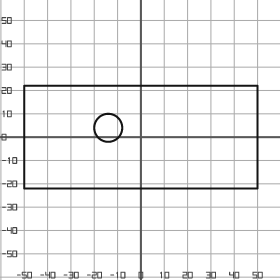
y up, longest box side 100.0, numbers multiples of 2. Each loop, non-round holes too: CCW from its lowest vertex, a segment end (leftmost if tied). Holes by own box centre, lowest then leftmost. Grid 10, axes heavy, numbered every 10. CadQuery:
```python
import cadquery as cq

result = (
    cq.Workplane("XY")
    .moveTo(-50.0, -22.0)
    .lineTo(50.0, -22.0)
    .lineTo(50.0, 22.0)
    .lineTo(-50.0, 22.0)
    .close()
    .moveTo(-14.0, 4.0)
    .circle(6.0)
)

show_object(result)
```